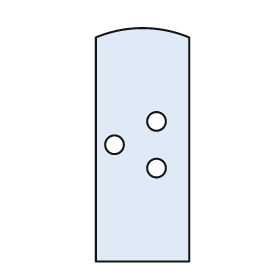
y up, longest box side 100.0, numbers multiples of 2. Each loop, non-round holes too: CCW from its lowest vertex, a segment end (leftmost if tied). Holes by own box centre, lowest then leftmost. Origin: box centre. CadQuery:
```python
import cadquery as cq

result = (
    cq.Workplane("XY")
    .moveTo(-20.0, -50.0)
    .lineTo(20.0, -50.0)
    .lineTo(20.0, 46.0)
    .threePointArc((0.0, 50.0), (-20.0, 46.0))
    .close()
    .moveTo(6.0, -10.0)
    .circle(4.0)
    .moveTo(-12.0, 0.0)
    .circle(4.0)
    .moveTo(6.0, 10.0)
    .circle(4.0)
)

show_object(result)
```